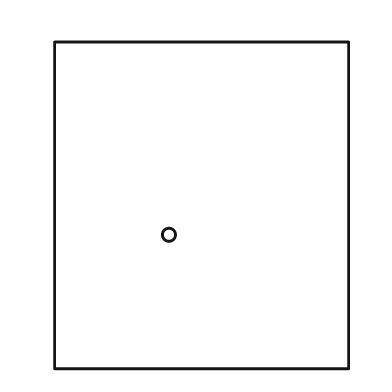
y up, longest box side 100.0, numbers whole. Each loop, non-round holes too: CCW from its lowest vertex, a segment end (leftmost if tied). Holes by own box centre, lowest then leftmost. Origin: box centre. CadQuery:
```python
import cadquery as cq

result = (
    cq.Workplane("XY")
    .moveTo(-45.0, -50.0)
    .lineTo(45.0, -50.0)
    .lineTo(45.0, 50.0)
    .lineTo(-45.0, 50.0)
    .close()
    .moveTo(-10.0, -9.0)
    .circle(2.0)
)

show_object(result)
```